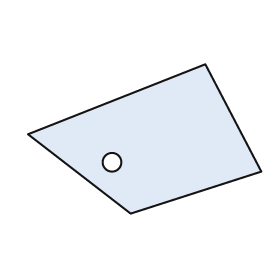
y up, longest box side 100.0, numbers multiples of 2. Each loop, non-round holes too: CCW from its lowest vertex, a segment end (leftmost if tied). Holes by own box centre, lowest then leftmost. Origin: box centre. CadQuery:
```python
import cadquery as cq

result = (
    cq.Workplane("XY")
    .moveTo(-6.0, -32.0)
    .lineTo(50.0, -14.0)
    .lineTo(26.0, 32.0)
    .lineTo(-50.0, 2.0)
    .close()
    .moveTo(-14.0, -10.0)
    .circle(4.0)
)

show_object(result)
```